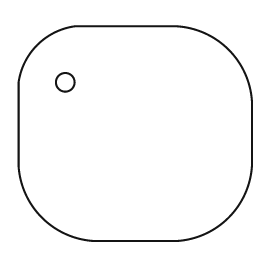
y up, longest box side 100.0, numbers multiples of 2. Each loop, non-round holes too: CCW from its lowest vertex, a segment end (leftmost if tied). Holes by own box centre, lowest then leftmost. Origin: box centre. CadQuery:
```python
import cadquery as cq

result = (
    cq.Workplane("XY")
    .moveTo(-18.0, -46.0)
    .lineTo(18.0, -46.0)
    .threePointArc((40.0, -36.0), (50.0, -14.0))
    .lineTo(50.0, 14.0)
    .threePointArc((40.0, 36.0), (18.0, 46.0))
    .lineTo(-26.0, 46.0)
    .threePointArc((-42.0, 38.0), (-50.0, 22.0))
    .lineTo(-50.0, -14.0)
    .threePointArc((-40.0, -36.0), (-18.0, -46.0))
    .close()
    .moveTo(-30.0, 22.0)
    .circle(4.0)
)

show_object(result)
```